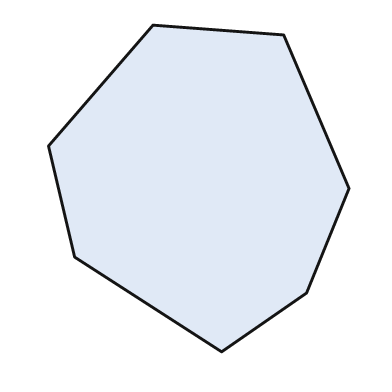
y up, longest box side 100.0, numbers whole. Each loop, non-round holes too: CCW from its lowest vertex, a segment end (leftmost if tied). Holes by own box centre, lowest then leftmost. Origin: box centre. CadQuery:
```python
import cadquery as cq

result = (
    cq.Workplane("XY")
    .moveTo(7.0, -50.0)
    .lineTo(33.0, -32.0)
    .lineTo(46.0, 0.0)
    .lineTo(26.0, 47.0)
    .lineTo(-14.0, 50.0)
    .lineTo(-46.0, 13.0)
    .lineTo(-38.0, -21.0)
    .close()
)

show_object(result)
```